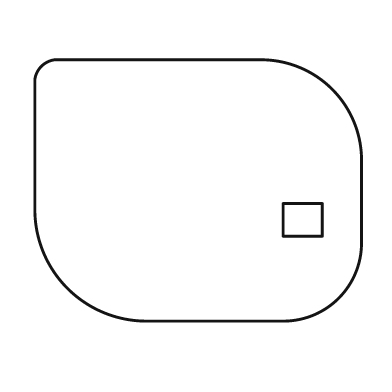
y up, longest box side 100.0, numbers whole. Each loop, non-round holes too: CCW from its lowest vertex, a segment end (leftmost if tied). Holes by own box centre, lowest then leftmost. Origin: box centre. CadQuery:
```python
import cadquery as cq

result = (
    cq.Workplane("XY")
    .moveTo(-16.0, -40.0)
    .lineTo(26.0, -40.0)
    .threePointArc((43.0, -33.0), (50.0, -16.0))
    .lineTo(50.0, 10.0)
    .threePointArc((41.0, 31.0), (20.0, 40.0))
    .lineTo(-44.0, 40.0)
    .threePointArc((-48.0, 38.0), (-50.0, 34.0))
    .lineTo(-50.0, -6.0)
    .threePointArc((-40.0, -30.0), (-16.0, -40.0))
    .close()
    .moveTo(26.0, -14.0)
    .lineTo(38.0, -14.0)
    .lineTo(38.0, -4.0)
    .lineTo(26.0, -4.0)
    .close()
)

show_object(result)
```